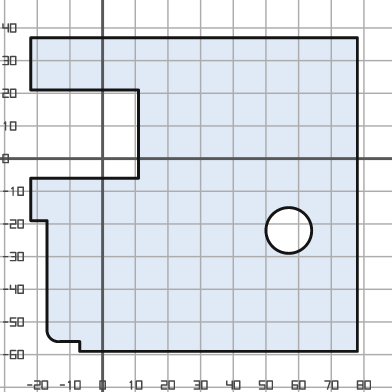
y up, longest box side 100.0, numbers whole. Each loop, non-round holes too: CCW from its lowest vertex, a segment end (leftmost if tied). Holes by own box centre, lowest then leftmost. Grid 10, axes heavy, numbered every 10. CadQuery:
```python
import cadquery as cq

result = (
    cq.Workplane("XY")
    .moveTo(-7.0, -59.0)
    .lineTo(78.0, -59.0)
    .lineTo(78.0, 37.0)
    .lineTo(-22.0, 37.0)
    .lineTo(-22.0, 21.0)
    .lineTo(11.0, 21.0)
    .lineTo(11.0, -6.0)
    .lineTo(-22.0, -6.0)
    .lineTo(-22.0, -19.0)
    .lineTo(-17.0, -19.0)
    .lineTo(-17.0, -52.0)
    .threePointArc((-16.0, -55.0), (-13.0, -56.0))
    .lineTo(-7.0, -56.0)
    .close()
    .moveTo(57.0, -22.0)
    .circle(7.0)
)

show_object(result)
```